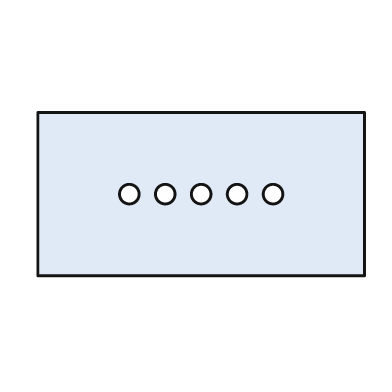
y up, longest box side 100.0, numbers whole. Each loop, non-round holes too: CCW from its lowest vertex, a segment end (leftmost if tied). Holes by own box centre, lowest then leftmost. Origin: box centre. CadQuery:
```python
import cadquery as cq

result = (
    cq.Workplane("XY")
    .moveTo(-50.0, -25.0)
    .lineTo(50.0, -25.0)
    .lineTo(50.0, 25.0)
    .lineTo(-50.0, 25.0)
    .close()
    .moveTo(-22.0, 0.0)
    .circle(3.0)
    .moveTo(-11.0, 0.0)
    .circle(3.0)
    .moveTo(0.0, 0.0)
    .circle(3.0)
    .moveTo(11.0, 0.0)
    .circle(3.0)
    .moveTo(22.0, 0.0)
    .circle(3.0)
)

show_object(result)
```